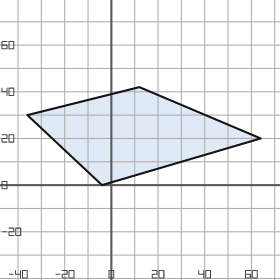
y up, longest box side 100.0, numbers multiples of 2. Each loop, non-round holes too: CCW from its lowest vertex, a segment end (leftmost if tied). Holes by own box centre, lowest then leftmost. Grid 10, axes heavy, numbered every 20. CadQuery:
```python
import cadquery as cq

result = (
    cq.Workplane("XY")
    .moveTo(-4.0, 0.0)
    .lineTo(64.0, 20.0)
    .lineTo(12.0, 42.0)
    .lineTo(-36.0, 30.0)
    .close()
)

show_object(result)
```